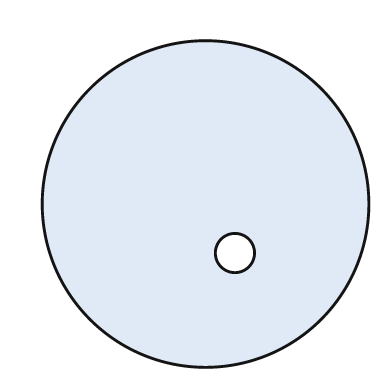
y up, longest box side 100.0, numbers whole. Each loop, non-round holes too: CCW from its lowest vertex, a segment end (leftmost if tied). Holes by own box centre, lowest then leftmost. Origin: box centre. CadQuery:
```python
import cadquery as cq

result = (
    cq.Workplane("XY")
    .moveTo(0.0, 0.0)
    .circle(50.0)
    .moveTo(9.0, -15.0)
    .circle(6.0)
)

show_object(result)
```